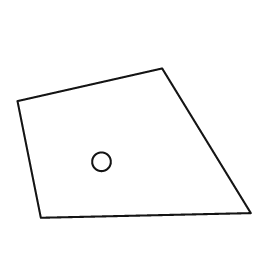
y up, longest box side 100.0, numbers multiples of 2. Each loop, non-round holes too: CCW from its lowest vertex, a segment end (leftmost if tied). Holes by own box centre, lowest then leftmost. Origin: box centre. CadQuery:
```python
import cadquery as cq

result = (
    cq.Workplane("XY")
    .moveTo(-40.0, -32.0)
    .lineTo(50.0, -30.0)
    .lineTo(12.0, 32.0)
    .lineTo(-50.0, 18.0)
    .close()
    .moveTo(-14.0, -8.0)
    .circle(4.0)
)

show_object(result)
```